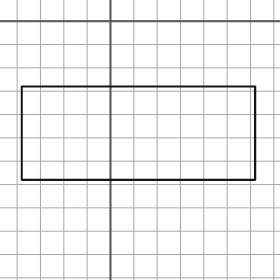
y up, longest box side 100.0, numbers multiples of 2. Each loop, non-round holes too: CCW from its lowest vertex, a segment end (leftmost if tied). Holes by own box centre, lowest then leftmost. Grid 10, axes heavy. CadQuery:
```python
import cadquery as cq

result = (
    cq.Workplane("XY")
    .moveTo(-38.0, -68.0)
    .lineTo(62.0, -68.0)
    .lineTo(62.0, -28.0)
    .lineTo(-38.0, -28.0)
    .close()
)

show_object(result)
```